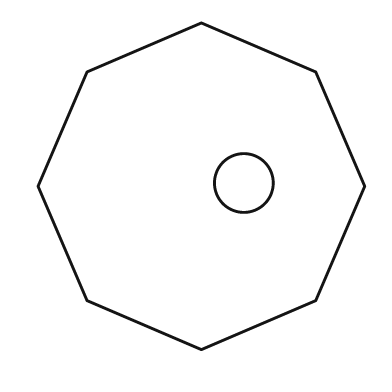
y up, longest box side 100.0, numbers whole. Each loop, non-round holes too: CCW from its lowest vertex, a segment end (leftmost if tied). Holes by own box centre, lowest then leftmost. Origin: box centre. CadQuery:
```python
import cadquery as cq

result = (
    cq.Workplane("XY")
    .moveTo(0.0, -50.0)
    .lineTo(35.0, -35.0)
    .lineTo(50.0, 0.0)
    .lineTo(35.0, 35.0)
    .lineTo(0.0, 50.0)
    .lineTo(-35.0, 35.0)
    .lineTo(-50.0, 0.0)
    .lineTo(-35.0, -35.0)
    .close()
    .moveTo(13.0, 1.0)
    .circle(9.0)
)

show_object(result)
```